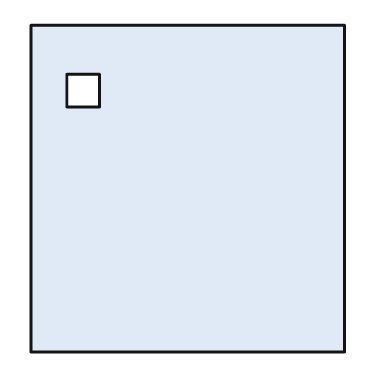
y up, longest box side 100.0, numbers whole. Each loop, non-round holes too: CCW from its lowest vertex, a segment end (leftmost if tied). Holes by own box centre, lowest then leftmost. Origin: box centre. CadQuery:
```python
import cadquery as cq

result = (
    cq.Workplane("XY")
    .moveTo(-48.0, -50.0)
    .lineTo(48.0, -50.0)
    .lineTo(48.0, 50.0)
    .lineTo(-48.0, 50.0)
    .close()
    .moveTo(-37.0, 25.0)
    .lineTo(-27.0, 25.0)
    .lineTo(-27.0, 35.0)
    .lineTo(-37.0, 35.0)
    .close()
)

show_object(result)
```